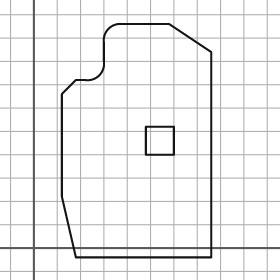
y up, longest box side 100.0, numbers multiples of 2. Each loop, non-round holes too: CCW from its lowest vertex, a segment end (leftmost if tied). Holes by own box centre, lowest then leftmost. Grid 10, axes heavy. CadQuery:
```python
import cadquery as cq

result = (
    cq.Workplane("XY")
    .moveTo(18.0, -4.0)
    .lineTo(76.0, -4.0)
    .lineTo(76.0, 84.0)
    .lineTo(58.0, 96.0)
    .lineTo(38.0, 96.0)
    .threePointArc((32.0, 94.0), (30.0, 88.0))
    .lineTo(30.0, 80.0)
    .threePointArc((28.0, 74.0), (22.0, 72.0))
    .lineTo(18.0, 72.0)
    .lineTo(12.0, 66.0)
    .lineTo(12.0, 22.0)
    .close()
    .moveTo(48.0, 40.0)
    .lineTo(60.0, 40.0)
    .lineTo(60.0, 52.0)
    .lineTo(48.0, 52.0)
    .close()
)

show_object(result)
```